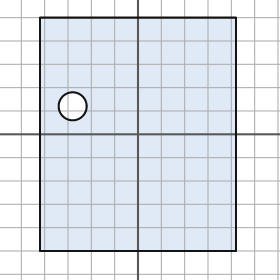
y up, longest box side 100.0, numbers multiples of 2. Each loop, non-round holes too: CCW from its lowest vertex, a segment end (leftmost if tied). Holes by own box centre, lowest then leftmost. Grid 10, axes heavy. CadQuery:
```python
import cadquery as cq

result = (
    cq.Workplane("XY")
    .moveTo(-42.0, -50.0)
    .lineTo(42.0, -50.0)
    .lineTo(42.0, 50.0)
    .lineTo(-42.0, 50.0)
    .close()
    .moveTo(-28.0, 12.0)
    .circle(6.0)
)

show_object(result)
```